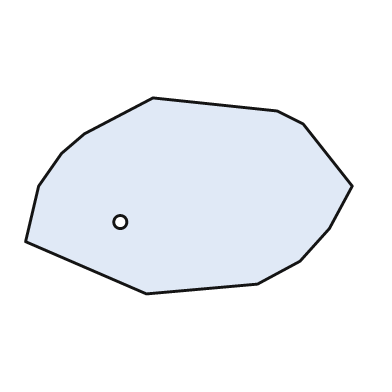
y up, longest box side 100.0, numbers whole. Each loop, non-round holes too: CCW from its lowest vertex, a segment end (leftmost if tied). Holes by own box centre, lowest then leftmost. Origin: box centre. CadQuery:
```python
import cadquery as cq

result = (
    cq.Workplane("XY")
    .moveTo(-13.0, -30.0)
    .lineTo(21.0, -27.0)
    .lineTo(34.0, -20.0)
    .lineTo(43.0, -10.0)
    .lineTo(50.0, 3.0)
    .lineTo(35.0, 22.0)
    .lineTo(27.0, 26.0)
    .lineTo(-11.0, 30.0)
    .lineTo(-32.0, 19.0)
    .lineTo(-39.0, 13.0)
    .lineTo(-46.0, 3.0)
    .lineTo(-50.0, -14.0)
    .close()
    .moveTo(-21.0, -8.0)
    .circle(2.0)
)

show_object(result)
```